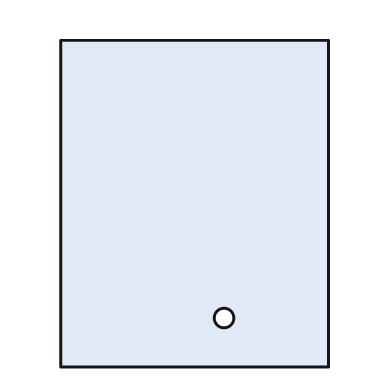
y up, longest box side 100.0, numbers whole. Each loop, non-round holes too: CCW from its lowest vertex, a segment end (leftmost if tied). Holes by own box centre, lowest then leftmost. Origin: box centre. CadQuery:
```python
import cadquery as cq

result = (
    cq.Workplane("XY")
    .moveTo(-41.0, -50.0)
    .lineTo(41.0, -50.0)
    .lineTo(41.0, 50.0)
    .lineTo(-41.0, 50.0)
    .close()
    .moveTo(9.0, -35.0)
    .circle(3.0)
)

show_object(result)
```